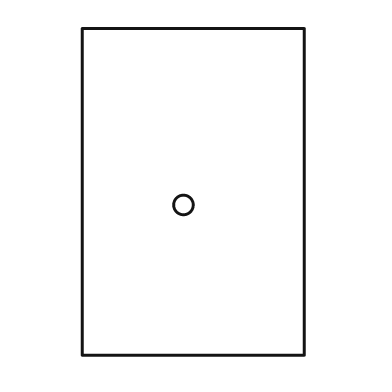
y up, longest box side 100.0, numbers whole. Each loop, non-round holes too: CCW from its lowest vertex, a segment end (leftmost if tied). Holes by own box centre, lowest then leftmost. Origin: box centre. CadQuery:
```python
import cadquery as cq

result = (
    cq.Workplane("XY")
    .moveTo(-34.0, -50.0)
    .lineTo(34.0, -50.0)
    .lineTo(34.0, 50.0)
    .lineTo(-34.0, 50.0)
    .close()
    .moveTo(-3.0, -4.0)
    .circle(3.0)
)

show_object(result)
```